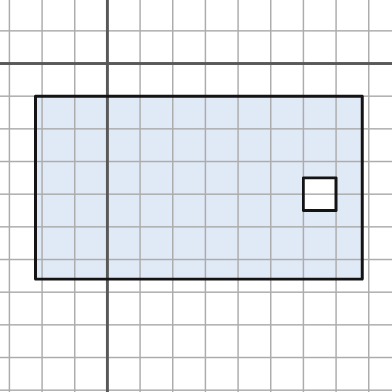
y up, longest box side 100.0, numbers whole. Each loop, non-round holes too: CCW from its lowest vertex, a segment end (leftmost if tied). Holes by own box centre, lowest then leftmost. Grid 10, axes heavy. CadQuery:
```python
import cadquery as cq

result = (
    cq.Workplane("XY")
    .moveTo(-22.0, -66.0)
    .lineTo(78.0, -66.0)
    .lineTo(78.0, -10.0)
    .lineTo(-22.0, -10.0)
    .close()
    .moveTo(60.0, -45.0)
    .lineTo(70.0, -45.0)
    .lineTo(70.0, -35.0)
    .lineTo(60.0, -35.0)
    .close()
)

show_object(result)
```